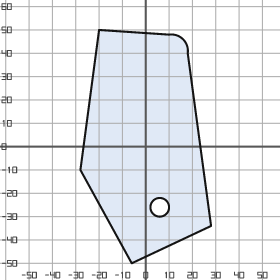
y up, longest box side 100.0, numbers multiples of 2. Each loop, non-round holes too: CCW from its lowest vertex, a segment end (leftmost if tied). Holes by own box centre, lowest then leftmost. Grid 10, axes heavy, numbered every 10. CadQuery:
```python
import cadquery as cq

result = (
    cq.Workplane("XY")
    .moveTo(-6.0, -50.0)
    .lineTo(28.0, -34.0)
    .lineTo(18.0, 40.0)
    .threePointArc((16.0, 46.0), (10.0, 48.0))
    .lineTo(-20.0, 50.0)
    .lineTo(-28.0, -10.0)
    .close()
    .moveTo(6.0, -26.0)
    .circle(4.0)
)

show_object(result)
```